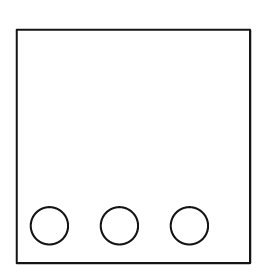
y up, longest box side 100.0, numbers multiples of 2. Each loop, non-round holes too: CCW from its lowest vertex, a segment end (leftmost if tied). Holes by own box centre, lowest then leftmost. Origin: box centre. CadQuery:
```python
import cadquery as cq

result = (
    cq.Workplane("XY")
    .moveTo(-50.0, -50.0)
    .lineTo(50.0, -50.0)
    .lineTo(50.0, 50.0)
    .lineTo(-50.0, 50.0)
    .close()
    .moveTo(-36.0, -34.0)
    .circle(8.0)
    .moveTo(-6.0, -34.0)
    .circle(8.0)
    .moveTo(24.0, -34.0)
    .circle(8.0)
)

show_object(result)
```